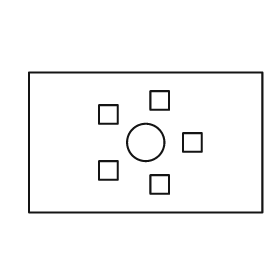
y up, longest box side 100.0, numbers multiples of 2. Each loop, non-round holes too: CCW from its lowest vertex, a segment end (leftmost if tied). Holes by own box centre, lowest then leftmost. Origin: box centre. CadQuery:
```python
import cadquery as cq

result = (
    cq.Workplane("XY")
    .moveTo(-50.0, -30.0)
    .lineTo(50.0, -30.0)
    .lineTo(50.0, 30.0)
    .lineTo(-50.0, 30.0)
    .close()
    .moveTo(2.0, -22.0)
    .lineTo(10.0, -22.0)
    .lineTo(10.0, -14.0)
    .lineTo(2.0, -14.0)
    .close()
    .moveTo(-20.0, -16.0)
    .lineTo(-12.0, -16.0)
    .lineTo(-12.0, -8.0)
    .lineTo(-20.0, -8.0)
    .close()
    .moveTo(0.0, 0.0)
    .circle(8.0)
    .moveTo(16.0, -4.0)
    .lineTo(24.0, -4.0)
    .lineTo(24.0, 4.0)
    .lineTo(16.0, 4.0)
    .close()
    .moveTo(-20.0, 8.0)
    .lineTo(-12.0, 8.0)
    .lineTo(-12.0, 16.0)
    .lineTo(-20.0, 16.0)
    .close()
    .moveTo(2.0, 14.0)
    .lineTo(10.0, 14.0)
    .lineTo(10.0, 22.0)
    .lineTo(2.0, 22.0)
    .close()
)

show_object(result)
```